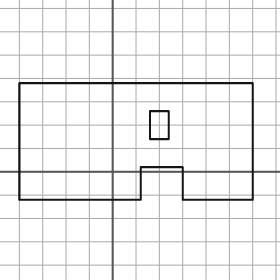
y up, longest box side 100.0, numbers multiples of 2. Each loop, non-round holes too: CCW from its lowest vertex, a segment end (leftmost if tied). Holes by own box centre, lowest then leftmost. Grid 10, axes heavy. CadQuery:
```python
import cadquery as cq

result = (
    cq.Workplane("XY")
    .moveTo(-40.0, -12.0)
    .lineTo(12.0, -12.0)
    .lineTo(12.0, 2.0)
    .lineTo(30.0, 2.0)
    .lineTo(30.0, -12.0)
    .lineTo(60.0, -12.0)
    .lineTo(60.0, 38.0)
    .lineTo(-40.0, 38.0)
    .close()
    .moveTo(16.0, 14.0)
    .lineTo(24.0, 14.0)
    .lineTo(24.0, 26.0)
    .lineTo(16.0, 26.0)
    .close()
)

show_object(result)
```